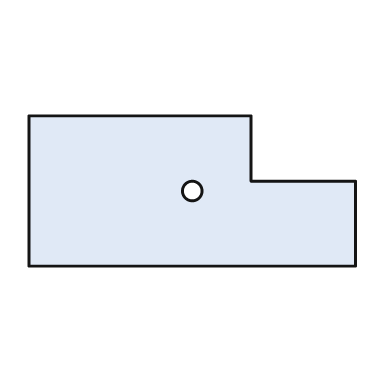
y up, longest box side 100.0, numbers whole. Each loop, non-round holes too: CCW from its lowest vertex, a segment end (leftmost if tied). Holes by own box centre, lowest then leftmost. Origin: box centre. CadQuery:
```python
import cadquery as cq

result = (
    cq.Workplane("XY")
    .moveTo(-50.0, -23.0)
    .lineTo(50.0, -23.0)
    .lineTo(50.0, 3.0)
    .lineTo(18.0, 3.0)
    .lineTo(18.0, 23.0)
    .lineTo(-50.0, 23.0)
    .close()
    .moveTo(0.0, 0.0)
    .circle(3.0)
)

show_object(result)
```